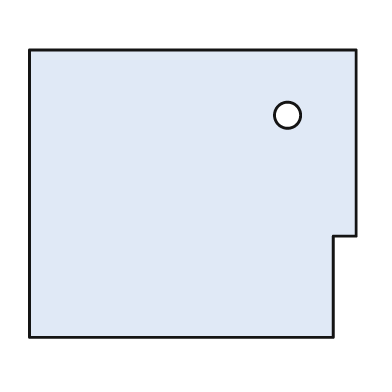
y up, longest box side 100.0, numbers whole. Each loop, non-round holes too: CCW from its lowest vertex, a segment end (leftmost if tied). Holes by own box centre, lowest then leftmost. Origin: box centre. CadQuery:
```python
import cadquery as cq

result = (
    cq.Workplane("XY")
    .moveTo(-50.0, -44.0)
    .lineTo(43.0, -44.0)
    .lineTo(43.0, -13.0)
    .lineTo(50.0, -13.0)
    .lineTo(50.0, 44.0)
    .lineTo(-50.0, 44.0)
    .close()
    .moveTo(29.0, 24.0)
    .circle(4.0)
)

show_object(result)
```